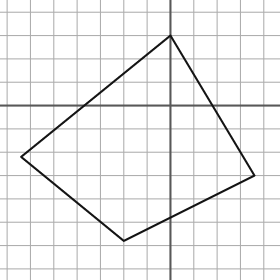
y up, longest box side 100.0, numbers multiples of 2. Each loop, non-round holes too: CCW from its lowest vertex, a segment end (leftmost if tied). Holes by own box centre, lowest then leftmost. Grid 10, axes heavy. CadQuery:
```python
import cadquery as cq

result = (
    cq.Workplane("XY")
    .moveTo(-20.0, -58.0)
    .lineTo(36.0, -30.0)
    .lineTo(0.0, 30.0)
    .lineTo(-64.0, -22.0)
    .close()
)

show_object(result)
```